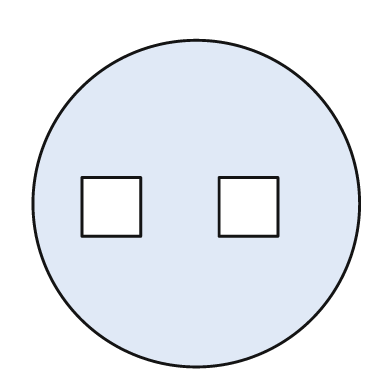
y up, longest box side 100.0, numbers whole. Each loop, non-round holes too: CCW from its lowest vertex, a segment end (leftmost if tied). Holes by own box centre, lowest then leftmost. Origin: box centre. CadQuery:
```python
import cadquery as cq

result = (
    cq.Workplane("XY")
    .moveTo(0.0, 0.0)
    .circle(50.0)
    .moveTo(-35.0, -10.0)
    .lineTo(-17.0, -10.0)
    .lineTo(-17.0, 8.0)
    .lineTo(-35.0, 8.0)
    .close()
    .moveTo(7.0, -10.0)
    .lineTo(25.0, -10.0)
    .lineTo(25.0, 8.0)
    .lineTo(7.0, 8.0)
    .close()
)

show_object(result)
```